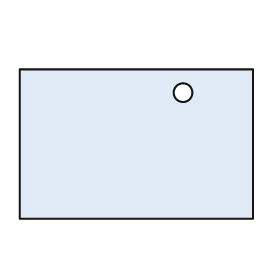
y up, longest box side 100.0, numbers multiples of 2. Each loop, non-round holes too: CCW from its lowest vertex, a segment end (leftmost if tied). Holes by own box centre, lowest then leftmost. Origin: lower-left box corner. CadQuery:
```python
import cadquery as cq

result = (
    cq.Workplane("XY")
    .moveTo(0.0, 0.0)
    .lineTo(100.0, 0.0)
    .lineTo(100.0, 64.0)
    .lineTo(0.0, 64.0)
    .close()
    .moveTo(70.0, 54.0)
    .circle(4.0)
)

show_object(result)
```